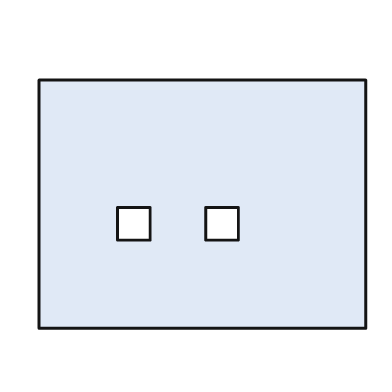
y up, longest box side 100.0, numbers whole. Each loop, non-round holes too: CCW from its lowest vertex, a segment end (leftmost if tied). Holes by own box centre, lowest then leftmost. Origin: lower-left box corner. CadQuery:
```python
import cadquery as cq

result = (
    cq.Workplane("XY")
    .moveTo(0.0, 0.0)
    .lineTo(100.0, 0.0)
    .lineTo(100.0, 76.0)
    .lineTo(0.0, 76.0)
    .close()
    .moveTo(24.0, 27.0)
    .lineTo(34.0, 27.0)
    .lineTo(34.0, 37.0)
    .lineTo(24.0, 37.0)
    .close()
    .moveTo(51.0, 27.0)
    .lineTo(61.0, 27.0)
    .lineTo(61.0, 37.0)
    .lineTo(51.0, 37.0)
    .close()
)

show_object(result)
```